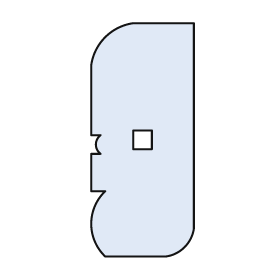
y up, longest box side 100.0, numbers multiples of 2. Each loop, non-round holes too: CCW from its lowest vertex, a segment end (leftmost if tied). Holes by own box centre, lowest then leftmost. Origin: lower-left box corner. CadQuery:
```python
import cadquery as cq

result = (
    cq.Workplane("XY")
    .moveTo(6.0, 0.0)
    .lineTo(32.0, 0.0)
    .threePointArc((40.0, 4.0), (44.0, 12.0))
    .lineTo(44.0, 100.0)
    .lineTo(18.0, 100.0)
    .threePointArc((6.0, 94.0), (0.0, 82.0))
    .lineTo(0.0, 52.0)
    .lineTo(4.0, 52.0)
    .threePointArc((2.0, 48.0), (4.0, 44.0))
    .lineTo(0.0, 44.0)
    .lineTo(0.0, 28.0)
    .lineTo(6.0, 28.0)
    .threePointArc((0.0, 14.0), (6.0, 0.0))
    .close()
    .moveTo(18.0, 46.0)
    .lineTo(26.0, 46.0)
    .lineTo(26.0, 54.0)
    .lineTo(18.0, 54.0)
    .close()
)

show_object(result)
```